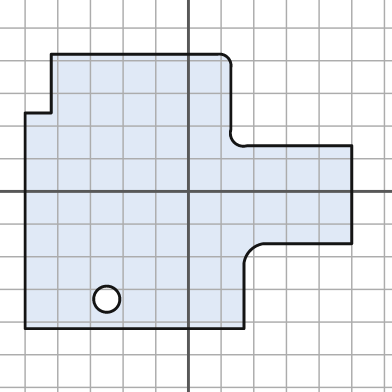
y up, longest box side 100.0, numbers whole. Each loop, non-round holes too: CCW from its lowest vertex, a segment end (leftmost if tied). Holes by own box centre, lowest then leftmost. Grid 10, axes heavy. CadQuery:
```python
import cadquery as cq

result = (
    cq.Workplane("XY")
    .moveTo(-50.0, -42.0)
    .lineTo(17.0, -42.0)
    .lineTo(17.0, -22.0)
    .threePointArc((19.0, -18.0), (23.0, -16.0))
    .lineTo(50.0, -16.0)
    .lineTo(50.0, 14.0)
    .lineTo(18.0, 14.0)
    .threePointArc((14.0, 15.0), (13.0, 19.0))
    .lineTo(13.0, 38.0)
    .threePointArc((12.0, 41.0), (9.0, 42.0))
    .lineTo(-42.0, 42.0)
    .lineTo(-42.0, 24.0)
    .lineTo(-50.0, 24.0)
    .close()
    .moveTo(-25.0, -33.0)
    .circle(4.0)
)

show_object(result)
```